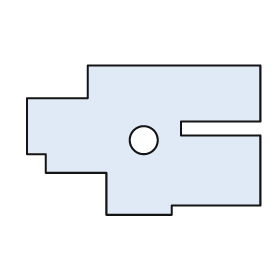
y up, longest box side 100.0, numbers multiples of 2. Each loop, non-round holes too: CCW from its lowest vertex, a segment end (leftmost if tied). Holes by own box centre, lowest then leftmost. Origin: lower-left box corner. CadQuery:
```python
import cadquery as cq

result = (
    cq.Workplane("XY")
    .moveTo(34.0, 0.0)
    .lineTo(62.0, 0.0)
    .lineTo(62.0, 4.0)
    .lineTo(100.0, 4.0)
    .lineTo(100.0, 34.0)
    .lineTo(66.0, 34.0)
    .lineTo(66.0, 40.0)
    .lineTo(100.0, 40.0)
    .lineTo(100.0, 64.0)
    .lineTo(26.0, 64.0)
    .lineTo(26.0, 50.0)
    .lineTo(0.0, 50.0)
    .lineTo(0.0, 26.0)
    .lineTo(8.0, 26.0)
    .lineTo(8.0, 18.0)
    .lineTo(34.0, 18.0)
    .close()
    .moveTo(50.0, 32.0)
    .circle(6.0)
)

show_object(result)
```